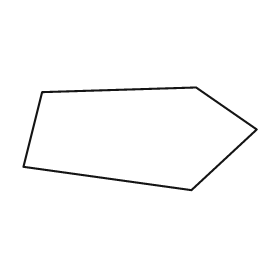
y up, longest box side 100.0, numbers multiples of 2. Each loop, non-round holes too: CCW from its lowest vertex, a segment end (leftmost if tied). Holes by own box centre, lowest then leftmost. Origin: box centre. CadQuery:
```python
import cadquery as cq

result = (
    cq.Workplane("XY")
    .moveTo(22.0, -22.0)
    .lineTo(50.0, 4.0)
    .lineTo(24.0, 22.0)
    .lineTo(-42.0, 20.0)
    .lineTo(-50.0, -12.0)
    .close()
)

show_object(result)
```